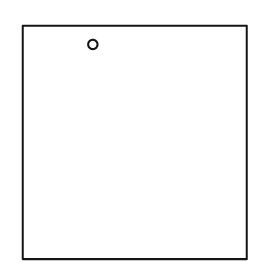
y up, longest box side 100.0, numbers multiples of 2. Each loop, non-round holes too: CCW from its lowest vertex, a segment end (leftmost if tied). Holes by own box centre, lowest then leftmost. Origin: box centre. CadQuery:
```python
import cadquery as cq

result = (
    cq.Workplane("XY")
    .moveTo(-48.0, -50.0)
    .lineTo(48.0, -50.0)
    .lineTo(48.0, 50.0)
    .lineTo(-48.0, 50.0)
    .close()
    .moveTo(-18.0, 42.0)
    .circle(2.0)
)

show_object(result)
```